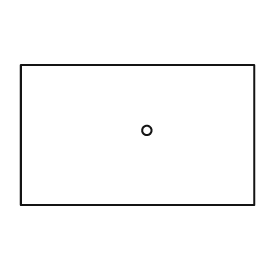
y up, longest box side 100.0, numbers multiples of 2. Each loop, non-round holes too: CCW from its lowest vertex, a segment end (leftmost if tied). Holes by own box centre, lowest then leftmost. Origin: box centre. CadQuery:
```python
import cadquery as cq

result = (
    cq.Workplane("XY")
    .moveTo(-50.0, -30.0)
    .lineTo(50.0, -30.0)
    .lineTo(50.0, 30.0)
    .lineTo(-50.0, 30.0)
    .close()
    .moveTo(4.0, 2.0)
    .circle(2.0)
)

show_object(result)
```